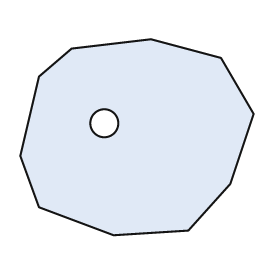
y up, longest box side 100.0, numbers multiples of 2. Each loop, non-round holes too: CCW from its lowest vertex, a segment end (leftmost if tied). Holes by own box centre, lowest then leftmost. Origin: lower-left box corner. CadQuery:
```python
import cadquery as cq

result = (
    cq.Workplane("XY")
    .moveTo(40.0, 0.0)
    .lineTo(72.0, 2.0)
    .lineTo(90.0, 22.0)
    .lineTo(100.0, 52.0)
    .lineTo(86.0, 76.0)
    .lineTo(56.0, 84.0)
    .lineTo(22.0, 80.0)
    .lineTo(8.0, 68.0)
    .lineTo(0.0, 34.0)
    .lineTo(8.0, 12.0)
    .close()
    .moveTo(36.0, 48.0)
    .circle(6.0)
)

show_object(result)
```